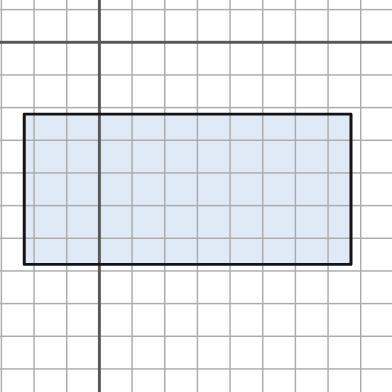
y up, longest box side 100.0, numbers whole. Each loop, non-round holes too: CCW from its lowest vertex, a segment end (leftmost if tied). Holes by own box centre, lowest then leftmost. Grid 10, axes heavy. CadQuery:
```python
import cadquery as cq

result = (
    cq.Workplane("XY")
    .moveTo(-23.0, -68.0)
    .lineTo(77.0, -68.0)
    .lineTo(77.0, -22.0)
    .lineTo(-23.0, -22.0)
    .close()
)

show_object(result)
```